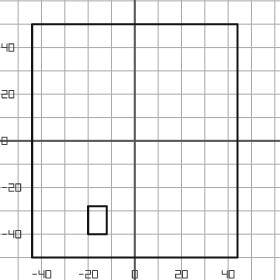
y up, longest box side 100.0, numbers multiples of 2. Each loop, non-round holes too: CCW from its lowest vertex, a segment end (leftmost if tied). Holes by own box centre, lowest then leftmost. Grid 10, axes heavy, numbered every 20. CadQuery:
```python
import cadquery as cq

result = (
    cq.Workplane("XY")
    .moveTo(-44.0, -50.0)
    .lineTo(44.0, -50.0)
    .lineTo(44.0, 50.0)
    .lineTo(-44.0, 50.0)
    .close()
    .moveTo(-20.0, -40.0)
    .lineTo(-12.0, -40.0)
    .lineTo(-12.0, -28.0)
    .lineTo(-20.0, -28.0)
    .close()
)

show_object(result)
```